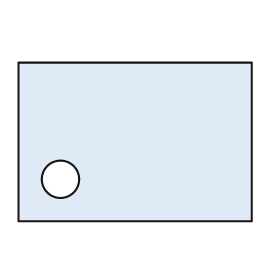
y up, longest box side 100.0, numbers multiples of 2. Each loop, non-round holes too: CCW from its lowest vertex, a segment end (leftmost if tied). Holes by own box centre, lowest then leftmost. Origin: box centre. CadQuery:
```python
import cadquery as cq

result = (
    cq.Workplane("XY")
    .moveTo(-50.0, -34.0)
    .lineTo(50.0, -34.0)
    .lineTo(50.0, 34.0)
    .lineTo(-50.0, 34.0)
    .close()
    .moveTo(-32.0, -16.0)
    .circle(8.0)
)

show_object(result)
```